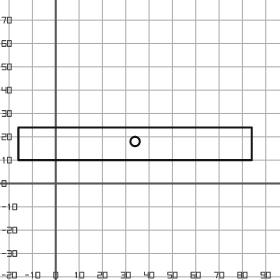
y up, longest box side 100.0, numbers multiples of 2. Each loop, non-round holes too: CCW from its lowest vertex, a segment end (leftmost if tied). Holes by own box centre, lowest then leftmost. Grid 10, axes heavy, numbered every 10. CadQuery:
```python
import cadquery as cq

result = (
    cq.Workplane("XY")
    .moveTo(-16.0, 10.0)
    .lineTo(84.0, 10.0)
    .lineTo(84.0, 24.0)
    .lineTo(-16.0, 24.0)
    .close()
    .moveTo(34.0, 18.0)
    .circle(2.0)
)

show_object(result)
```